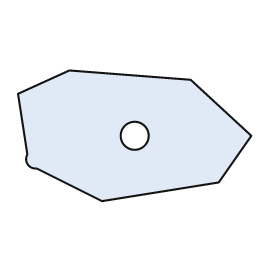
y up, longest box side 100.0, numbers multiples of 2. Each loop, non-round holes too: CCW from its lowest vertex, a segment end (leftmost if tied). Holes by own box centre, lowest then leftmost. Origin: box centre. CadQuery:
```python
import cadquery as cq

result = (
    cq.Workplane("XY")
    .moveTo(-14.0, -28.0)
    .lineTo(36.0, -20.0)
    .lineTo(50.0, 0.0)
    .lineTo(24.0, 24.0)
    .lineTo(-28.0, 28.0)
    .lineTo(-50.0, 18.0)
    .lineTo(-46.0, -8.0)
    .threePointArc((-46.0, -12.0), (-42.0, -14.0))
    .close()
    .moveTo(0.0, 0.0)
    .circle(6.0)
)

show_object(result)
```